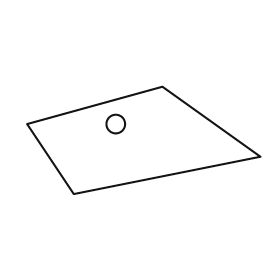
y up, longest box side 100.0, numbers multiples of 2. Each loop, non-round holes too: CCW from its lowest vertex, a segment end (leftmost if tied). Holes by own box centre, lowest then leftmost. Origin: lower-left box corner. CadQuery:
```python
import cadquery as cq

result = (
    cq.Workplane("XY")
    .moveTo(20.0, 0.0)
    .lineTo(100.0, 16.0)
    .lineTo(58.0, 46.0)
    .lineTo(0.0, 30.0)
    .close()
    .moveTo(38.0, 30.0)
    .circle(4.0)
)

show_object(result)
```